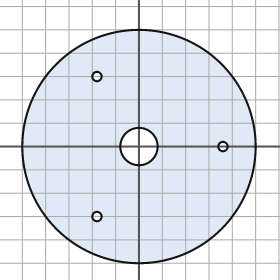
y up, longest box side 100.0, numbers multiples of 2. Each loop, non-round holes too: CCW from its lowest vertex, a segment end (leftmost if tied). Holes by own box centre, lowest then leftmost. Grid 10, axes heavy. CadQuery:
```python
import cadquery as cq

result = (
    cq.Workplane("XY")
    .moveTo(0.0, 0.0)
    .circle(50.0)
    .moveTo(-18.0, -30.0)
    .circle(2.0)
    .moveTo(0.0, 0.0)
    .circle(8.0)
    .moveTo(36.0, 0.0)
    .circle(2.0)
    .moveTo(-18.0, 30.0)
    .circle(2.0)
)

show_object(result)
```